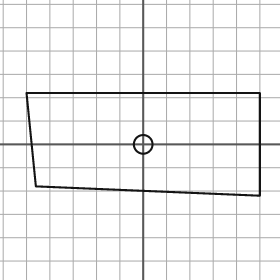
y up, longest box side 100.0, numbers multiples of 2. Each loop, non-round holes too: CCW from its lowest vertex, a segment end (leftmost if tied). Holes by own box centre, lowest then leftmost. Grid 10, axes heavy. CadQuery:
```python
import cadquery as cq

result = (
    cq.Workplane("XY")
    .moveTo(50.0, -22.0)
    .lineTo(50.0, 22.0)
    .lineTo(-50.0, 22.0)
    .lineTo(-46.0, -18.0)
    .close()
    .moveTo(0.0, 0.0)
    .circle(4.0)
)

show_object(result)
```